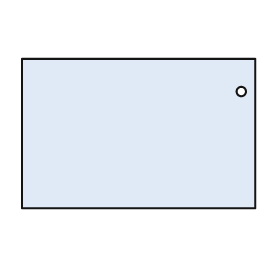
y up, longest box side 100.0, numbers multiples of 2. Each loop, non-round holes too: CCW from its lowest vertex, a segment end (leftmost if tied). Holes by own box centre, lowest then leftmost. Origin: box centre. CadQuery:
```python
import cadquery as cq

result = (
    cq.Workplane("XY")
    .moveTo(-50.0, -32.0)
    .lineTo(50.0, -32.0)
    .lineTo(50.0, 32.0)
    .lineTo(-50.0, 32.0)
    .close()
    .moveTo(44.0, 18.0)
    .circle(2.0)
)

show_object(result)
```